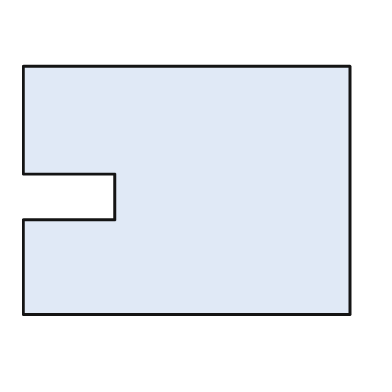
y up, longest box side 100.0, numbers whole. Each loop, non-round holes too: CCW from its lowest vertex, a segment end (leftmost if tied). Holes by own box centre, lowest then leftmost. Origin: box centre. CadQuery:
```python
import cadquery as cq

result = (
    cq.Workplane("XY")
    .moveTo(-50.0, -38.0)
    .lineTo(50.0, -38.0)
    .lineTo(50.0, 38.0)
    .lineTo(-50.0, 38.0)
    .lineTo(-50.0, 5.0)
    .lineTo(-22.0, 5.0)
    .lineTo(-22.0, -9.0)
    .lineTo(-50.0, -9.0)
    .close()
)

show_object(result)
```